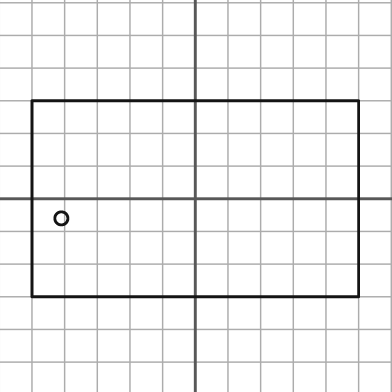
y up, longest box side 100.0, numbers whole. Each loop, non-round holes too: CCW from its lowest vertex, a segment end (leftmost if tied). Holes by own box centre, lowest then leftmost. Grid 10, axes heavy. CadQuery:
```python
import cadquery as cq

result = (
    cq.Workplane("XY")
    .moveTo(-50.0, -30.0)
    .lineTo(50.0, -30.0)
    .lineTo(50.0, 30.0)
    .lineTo(-50.0, 30.0)
    .close()
    .moveTo(-41.0, -6.0)
    .circle(2.0)
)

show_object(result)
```